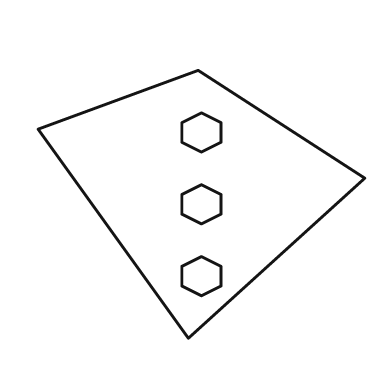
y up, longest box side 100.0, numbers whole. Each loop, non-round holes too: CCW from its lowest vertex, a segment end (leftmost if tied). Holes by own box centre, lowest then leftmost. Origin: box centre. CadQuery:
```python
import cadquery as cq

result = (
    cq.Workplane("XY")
    .moveTo(-4.0, -41.0)
    .lineTo(50.0, 8.0)
    .lineTo(-1.0, 41.0)
    .lineTo(-50.0, 23.0)
    .close()
    .moveTo(0.0, -28.0)
    .lineTo(6.0, -25.0)
    .lineTo(6.0, -19.0)
    .lineTo(0.0, -16.0)
    .lineTo(-6.0, -19.0)
    .lineTo(-6.0, -25.0)
    .close()
    .moveTo(0.0, -6.0)
    .lineTo(6.0, -3.0)
    .lineTo(6.0, 3.0)
    .lineTo(0.0, 6.0)
    .lineTo(-6.0, 3.0)
    .lineTo(-6.0, -3.0)
    .close()
    .moveTo(0.0, 16.0)
    .lineTo(6.0, 19.0)
    .lineTo(6.0, 25.0)
    .lineTo(0.0, 28.0)
    .lineTo(-6.0, 25.0)
    .lineTo(-6.0, 19.0)
    .close()
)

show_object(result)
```